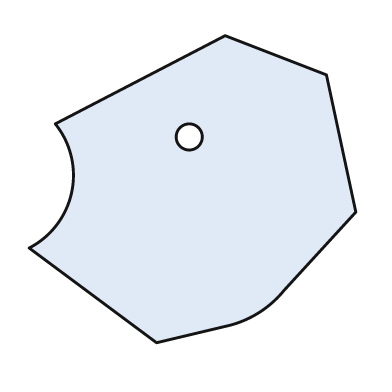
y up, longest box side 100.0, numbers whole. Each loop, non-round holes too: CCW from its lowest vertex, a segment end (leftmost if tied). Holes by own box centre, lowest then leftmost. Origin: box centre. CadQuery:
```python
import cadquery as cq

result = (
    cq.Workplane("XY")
    .moveTo(-11.0, -47.0)
    .lineTo(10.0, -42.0)
    .threePointArc((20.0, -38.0), (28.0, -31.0))
    .lineTo(50.0, -7.0)
    .lineTo(41.0, 35.0)
    .lineTo(10.0, 47.0)
    .lineTo(-42.0, 20.0)
    .threePointArc((-37.0, -1.0), (-50.0, -18.0))
    .close()
    .moveTo(-1.0, 16.0)
    .circle(4.0)
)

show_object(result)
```